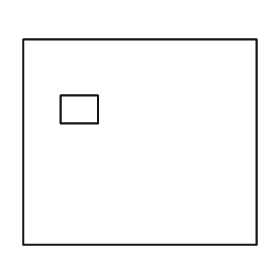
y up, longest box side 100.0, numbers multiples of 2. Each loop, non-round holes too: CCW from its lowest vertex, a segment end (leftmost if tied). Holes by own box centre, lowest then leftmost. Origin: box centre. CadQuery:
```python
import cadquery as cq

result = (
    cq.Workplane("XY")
    .moveTo(-50.0, -44.0)
    .lineTo(50.0, -44.0)
    .lineTo(50.0, 44.0)
    .lineTo(-50.0, 44.0)
    .close()
    .moveTo(-34.0, 8.0)
    .lineTo(-18.0, 8.0)
    .lineTo(-18.0, 20.0)
    .lineTo(-34.0, 20.0)
    .close()
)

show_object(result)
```